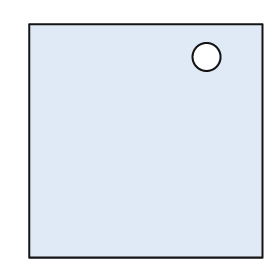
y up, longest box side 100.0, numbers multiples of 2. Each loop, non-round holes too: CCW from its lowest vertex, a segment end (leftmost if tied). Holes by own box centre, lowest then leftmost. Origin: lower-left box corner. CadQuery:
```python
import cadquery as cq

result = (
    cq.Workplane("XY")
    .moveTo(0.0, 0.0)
    .lineTo(100.0, 0.0)
    .lineTo(100.0, 100.0)
    .lineTo(0.0, 100.0)
    .close()
    .moveTo(76.0, 86.0)
    .circle(6.0)
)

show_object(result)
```